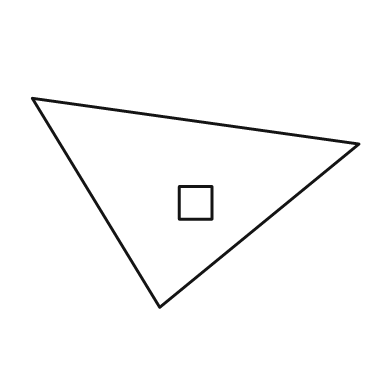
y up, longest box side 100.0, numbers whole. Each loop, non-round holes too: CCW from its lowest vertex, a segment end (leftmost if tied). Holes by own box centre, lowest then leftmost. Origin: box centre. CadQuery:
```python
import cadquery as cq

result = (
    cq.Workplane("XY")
    .moveTo(-11.0, -32.0)
    .lineTo(50.0, 18.0)
    .lineTo(-50.0, 32.0)
    .close()
    .moveTo(-5.0, -5.0)
    .lineTo(5.0, -5.0)
    .lineTo(5.0, 5.0)
    .lineTo(-5.0, 5.0)
    .close()
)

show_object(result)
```